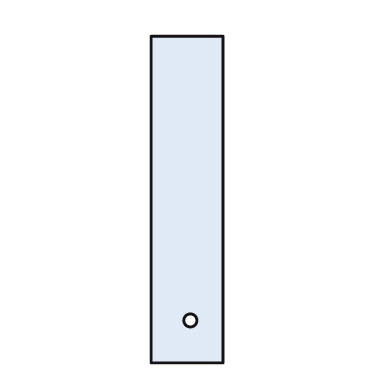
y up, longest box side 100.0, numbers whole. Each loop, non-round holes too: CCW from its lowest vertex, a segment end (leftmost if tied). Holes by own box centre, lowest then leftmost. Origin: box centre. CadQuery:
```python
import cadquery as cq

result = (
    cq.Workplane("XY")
    .moveTo(-11.0, -50.0)
    .lineTo(11.0, -50.0)
    .lineTo(11.0, 50.0)
    .lineTo(-11.0, 50.0)
    .close()
    .moveTo(1.0, -37.0)
    .circle(2.0)
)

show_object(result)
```